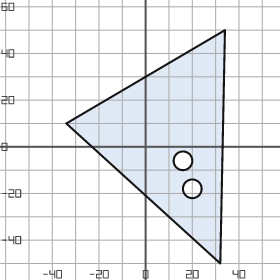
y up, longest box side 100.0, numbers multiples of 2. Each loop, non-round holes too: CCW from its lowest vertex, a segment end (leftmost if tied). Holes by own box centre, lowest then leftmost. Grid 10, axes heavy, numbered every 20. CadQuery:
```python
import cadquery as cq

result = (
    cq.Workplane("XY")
    .moveTo(32.0, -50.0)
    .lineTo(34.0, 50.0)
    .lineTo(-34.0, 10.0)
    .close()
    .moveTo(20.0, -18.0)
    .circle(4.0)
    .moveTo(16.0, -6.0)
    .circle(4.0)
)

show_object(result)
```